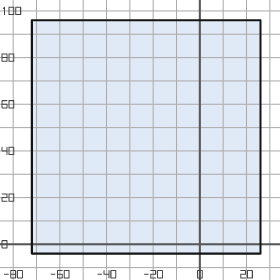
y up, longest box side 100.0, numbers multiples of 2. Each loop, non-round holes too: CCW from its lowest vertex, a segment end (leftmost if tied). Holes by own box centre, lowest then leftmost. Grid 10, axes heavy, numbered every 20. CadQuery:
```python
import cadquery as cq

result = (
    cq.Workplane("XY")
    .moveTo(-72.0, -4.0)
    .lineTo(26.0, -4.0)
    .lineTo(26.0, 96.0)
    .lineTo(-72.0, 96.0)
    .close()
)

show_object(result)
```